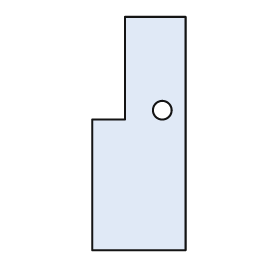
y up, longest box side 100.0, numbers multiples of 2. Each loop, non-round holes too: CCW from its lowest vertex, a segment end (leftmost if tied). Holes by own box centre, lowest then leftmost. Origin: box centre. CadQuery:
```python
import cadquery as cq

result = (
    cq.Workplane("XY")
    .moveTo(-20.0, -50.0)
    .lineTo(20.0, -50.0)
    .lineTo(20.0, 50.0)
    .lineTo(-6.0, 50.0)
    .lineTo(-6.0, 6.0)
    .lineTo(-20.0, 6.0)
    .close()
    .moveTo(10.0, 10.0)
    .circle(4.0)
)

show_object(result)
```